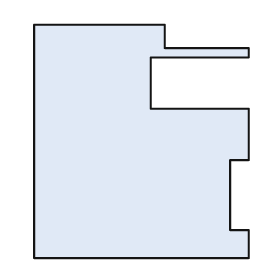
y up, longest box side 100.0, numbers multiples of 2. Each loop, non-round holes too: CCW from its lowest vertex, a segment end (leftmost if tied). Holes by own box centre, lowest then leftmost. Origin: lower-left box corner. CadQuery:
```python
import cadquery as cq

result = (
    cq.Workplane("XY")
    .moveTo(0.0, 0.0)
    .lineTo(92.0, 0.0)
    .lineTo(92.0, 12.0)
    .lineTo(84.0, 12.0)
    .lineTo(84.0, 42.0)
    .lineTo(92.0, 42.0)
    .lineTo(92.0, 64.0)
    .lineTo(50.0, 64.0)
    .lineTo(50.0, 86.0)
    .lineTo(92.0, 86.0)
    .lineTo(92.0, 90.0)
    .lineTo(56.0, 90.0)
    .lineTo(56.0, 100.0)
    .lineTo(0.0, 100.0)
    .close()
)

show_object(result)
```